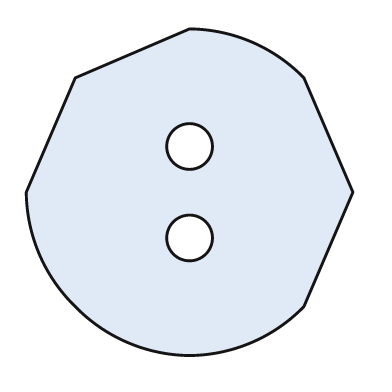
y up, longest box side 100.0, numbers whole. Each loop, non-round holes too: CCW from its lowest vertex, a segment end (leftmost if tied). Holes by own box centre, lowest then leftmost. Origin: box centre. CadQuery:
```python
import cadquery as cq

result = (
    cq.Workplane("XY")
    .moveTo(0.0, -50.0)
    .threePointArc((19.0, -46.0), (35.0, -35.0))
    .lineTo(50.0, 0.0)
    .lineTo(35.0, 35.0)
    .threePointArc((19.0, 46.0), (0.0, 50.0))
    .lineTo(-35.0, 35.0)
    .lineTo(-50.0, 0.0)
    .threePointArc((-46.0, -19.0), (-35.0, -35.0))
    .threePointArc((-19.0, -46.0), (0.0, -50.0))
    .close()
    .moveTo(0.0, -14.0)
    .circle(7.0)
    .moveTo(0.0, 14.0)
    .circle(7.0)
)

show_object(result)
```